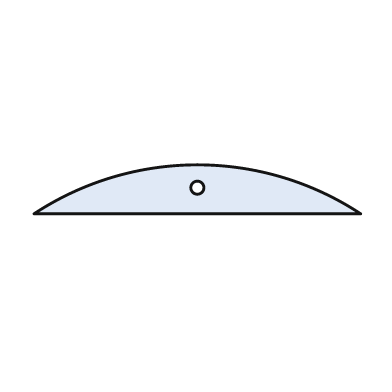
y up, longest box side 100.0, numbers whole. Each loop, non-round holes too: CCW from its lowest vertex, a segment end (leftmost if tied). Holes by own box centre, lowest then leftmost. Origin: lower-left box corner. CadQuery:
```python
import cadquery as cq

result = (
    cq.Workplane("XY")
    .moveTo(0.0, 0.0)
    .lineTo(100.0, 0.0)
    .threePointArc((50.0, 15.0), (0.0, 0.0))
    .close()
    .moveTo(50.0, 8.0)
    .circle(2.0)
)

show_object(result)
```